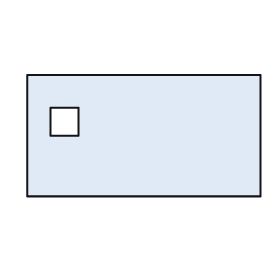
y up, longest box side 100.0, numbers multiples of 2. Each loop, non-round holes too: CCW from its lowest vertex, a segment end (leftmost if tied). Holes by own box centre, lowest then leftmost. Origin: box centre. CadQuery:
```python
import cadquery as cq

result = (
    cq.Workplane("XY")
    .moveTo(-50.0, -26.0)
    .lineTo(50.0, -26.0)
    .lineTo(50.0, 26.0)
    .lineTo(-50.0, 26.0)
    .close()
    .moveTo(-40.0, 0.0)
    .lineTo(-28.0, 0.0)
    .lineTo(-28.0, 12.0)
    .lineTo(-40.0, 12.0)
    .close()
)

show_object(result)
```